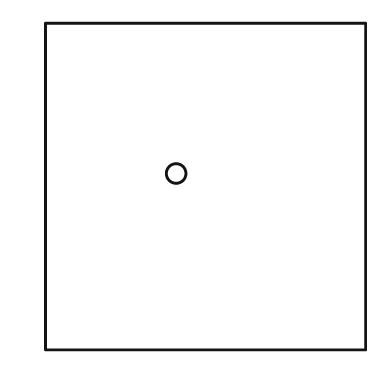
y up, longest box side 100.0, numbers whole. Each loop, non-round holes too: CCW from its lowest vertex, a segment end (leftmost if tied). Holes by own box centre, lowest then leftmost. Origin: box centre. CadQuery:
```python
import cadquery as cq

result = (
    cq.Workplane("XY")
    .moveTo(-49.0, -50.0)
    .lineTo(49.0, -50.0)
    .lineTo(49.0, 50.0)
    .lineTo(-49.0, 50.0)
    .close()
    .moveTo(-9.0, 4.0)
    .circle(3.0)
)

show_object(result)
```